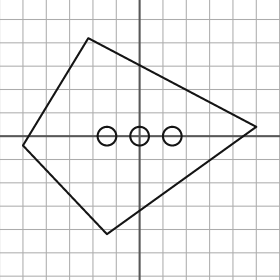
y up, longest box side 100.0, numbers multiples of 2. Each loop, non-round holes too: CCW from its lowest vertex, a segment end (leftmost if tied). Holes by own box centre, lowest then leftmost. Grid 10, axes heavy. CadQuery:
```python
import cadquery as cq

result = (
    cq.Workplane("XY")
    .moveTo(-14.0, -42.0)
    .lineTo(50.0, 4.0)
    .lineTo(-22.0, 42.0)
    .lineTo(-50.0, -4.0)
    .close()
    .moveTo(-14.0, 0.0)
    .circle(4.0)
    .moveTo(0.0, 0.0)
    .circle(4.0)
    .moveTo(14.0, 0.0)
    .circle(4.0)
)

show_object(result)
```